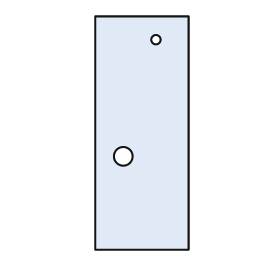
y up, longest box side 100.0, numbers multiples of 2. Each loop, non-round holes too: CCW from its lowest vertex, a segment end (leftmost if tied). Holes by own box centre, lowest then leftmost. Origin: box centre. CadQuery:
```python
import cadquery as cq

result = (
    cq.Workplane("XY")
    .moveTo(-20.0, -50.0)
    .lineTo(20.0, -50.0)
    .lineTo(20.0, 50.0)
    .lineTo(-20.0, 50.0)
    .close()
    .moveTo(-8.0, -10.0)
    .circle(4.0)
    .moveTo(6.0, 40.0)
    .circle(2.0)
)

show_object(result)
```